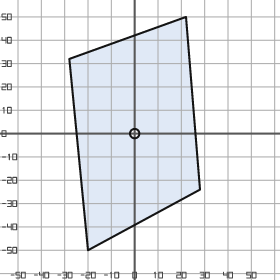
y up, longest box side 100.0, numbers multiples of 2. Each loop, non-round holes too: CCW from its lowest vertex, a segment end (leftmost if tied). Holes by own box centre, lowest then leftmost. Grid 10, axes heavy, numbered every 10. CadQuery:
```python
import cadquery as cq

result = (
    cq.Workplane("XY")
    .moveTo(-20.0, -50.0)
    .lineTo(28.0, -24.0)
    .lineTo(22.0, 50.0)
    .lineTo(-28.0, 32.0)
    .close()
    .moveTo(0.0, 0.0)
    .circle(2.0)
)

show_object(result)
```